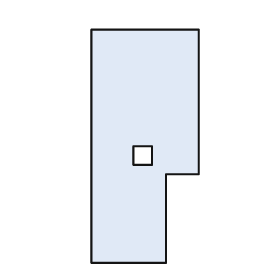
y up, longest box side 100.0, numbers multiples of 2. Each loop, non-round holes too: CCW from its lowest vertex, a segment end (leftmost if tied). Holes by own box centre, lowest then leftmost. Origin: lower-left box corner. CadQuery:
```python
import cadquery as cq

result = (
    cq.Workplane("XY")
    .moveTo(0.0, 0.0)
    .lineTo(32.0, 0.0)
    .lineTo(32.0, 38.0)
    .lineTo(46.0, 38.0)
    .lineTo(46.0, 100.0)
    .lineTo(0.0, 100.0)
    .close()
    .moveTo(18.0, 42.0)
    .lineTo(26.0, 42.0)
    .lineTo(26.0, 50.0)
    .lineTo(18.0, 50.0)
    .close()
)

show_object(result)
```